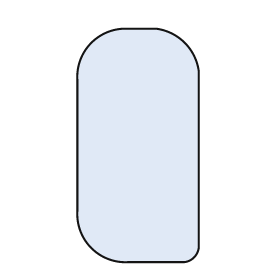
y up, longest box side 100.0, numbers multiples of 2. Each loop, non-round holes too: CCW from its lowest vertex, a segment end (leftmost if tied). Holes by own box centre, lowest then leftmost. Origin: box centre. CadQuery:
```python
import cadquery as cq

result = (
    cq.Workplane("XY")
    .moveTo(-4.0, -50.0)
    .lineTo(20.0, -50.0)
    .threePointArc((24.0, -48.0), (26.0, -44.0))
    .lineTo(26.0, 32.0)
    .threePointArc((20.0, 44.0), (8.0, 50.0))
    .lineTo(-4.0, 50.0)
    .threePointArc((-20.0, 44.0), (-26.0, 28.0))
    .lineTo(-26.0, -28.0)
    .threePointArc((-20.0, -44.0), (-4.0, -50.0))
    .close()
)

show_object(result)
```